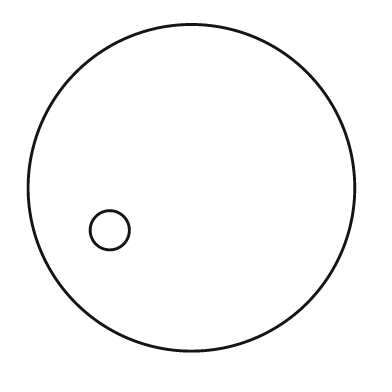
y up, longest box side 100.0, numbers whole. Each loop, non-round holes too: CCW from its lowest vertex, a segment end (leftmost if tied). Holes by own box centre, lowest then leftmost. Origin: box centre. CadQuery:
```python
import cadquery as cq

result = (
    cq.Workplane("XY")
    .moveTo(0.0, 0.0)
    .circle(50.0)
    .moveTo(-25.0, -13.0)
    .circle(6.0)
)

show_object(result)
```